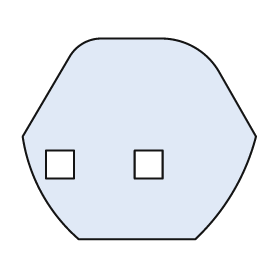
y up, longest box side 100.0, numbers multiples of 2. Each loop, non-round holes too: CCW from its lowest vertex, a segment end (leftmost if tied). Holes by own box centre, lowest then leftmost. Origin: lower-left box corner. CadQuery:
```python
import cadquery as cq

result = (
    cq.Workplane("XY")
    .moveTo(24.0, 0.0)
    .lineTo(74.0, 0.0)
    .threePointArc((90.0, 20.0), (100.0, 44.0))
    .lineTo(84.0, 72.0)
    .threePointArc((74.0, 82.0), (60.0, 86.0))
    .lineTo(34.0, 86.0)
    .threePointArc((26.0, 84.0), (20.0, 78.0))
    .lineTo(0.0, 44.0)
    .threePointArc((8.0, 20.0), (24.0, 0.0))
    .close()
    .moveTo(10.0, 26.0)
    .lineTo(22.0, 26.0)
    .lineTo(22.0, 38.0)
    .lineTo(10.0, 38.0)
    .close()
    .moveTo(48.0, 26.0)
    .lineTo(60.0, 26.0)
    .lineTo(60.0, 38.0)
    .lineTo(48.0, 38.0)
    .close()
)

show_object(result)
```